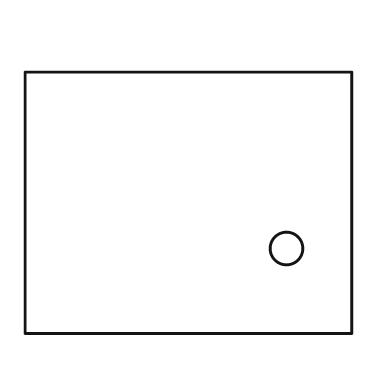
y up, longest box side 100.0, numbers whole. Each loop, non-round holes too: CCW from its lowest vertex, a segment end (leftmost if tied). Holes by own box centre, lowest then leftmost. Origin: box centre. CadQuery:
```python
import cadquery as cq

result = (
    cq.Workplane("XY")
    .moveTo(-50.0, -40.0)
    .lineTo(50.0, -40.0)
    .lineTo(50.0, 40.0)
    .lineTo(-50.0, 40.0)
    .close()
    .moveTo(30.0, -14.0)
    .circle(5.0)
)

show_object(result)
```